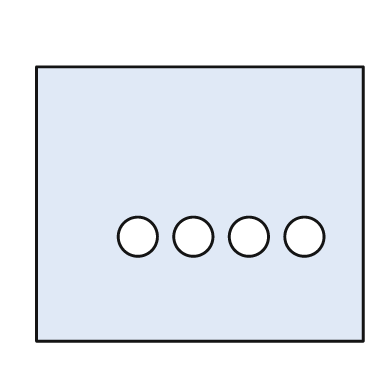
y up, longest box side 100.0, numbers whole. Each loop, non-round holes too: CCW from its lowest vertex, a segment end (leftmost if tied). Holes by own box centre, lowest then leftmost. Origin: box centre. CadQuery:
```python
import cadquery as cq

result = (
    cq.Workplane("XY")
    .moveTo(-50.0, -42.0)
    .lineTo(50.0, -42.0)
    .lineTo(50.0, 42.0)
    .lineTo(-50.0, 42.0)
    .close()
    .moveTo(-19.0, -10.0)
    .circle(6.0)
    .moveTo(-2.0, -10.0)
    .circle(6.0)
    .moveTo(15.0, -10.0)
    .circle(6.0)
    .moveTo(32.0, -10.0)
    .circle(6.0)
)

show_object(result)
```